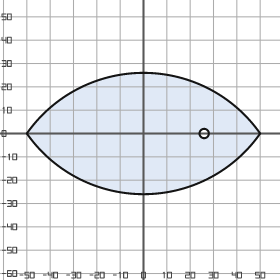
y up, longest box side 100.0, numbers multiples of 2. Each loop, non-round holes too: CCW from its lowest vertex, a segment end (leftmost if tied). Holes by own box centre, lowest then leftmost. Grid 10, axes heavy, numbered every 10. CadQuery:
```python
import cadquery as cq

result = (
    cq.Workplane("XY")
    .moveTo(-50.0, 0.0)
    .threePointArc((0.0, -26.0), (50.0, 0.0))
    .threePointArc((0.0, 26.0), (-50.0, 0.0))
    .close()
    .moveTo(26.0, 0.0)
    .circle(2.0)
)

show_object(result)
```